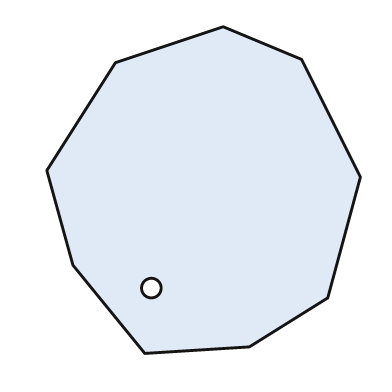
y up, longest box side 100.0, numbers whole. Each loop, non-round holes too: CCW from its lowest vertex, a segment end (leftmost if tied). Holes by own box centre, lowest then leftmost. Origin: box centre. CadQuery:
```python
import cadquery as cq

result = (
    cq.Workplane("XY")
    .moveTo(-18.0, -50.0)
    .lineTo(14.0, -48.0)
    .lineTo(38.0, -33.0)
    .lineTo(48.0, 4.0)
    .lineTo(30.0, 40.0)
    .lineTo(6.0, 50.0)
    .lineTo(-27.0, 39.0)
    .lineTo(-48.0, 6.0)
    .lineTo(-40.0, -23.0)
    .close()
    .moveTo(-16.0, -30.0)
    .circle(3.0)
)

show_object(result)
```